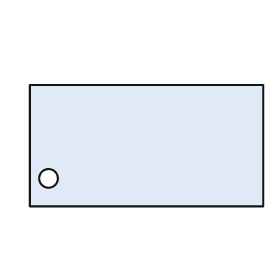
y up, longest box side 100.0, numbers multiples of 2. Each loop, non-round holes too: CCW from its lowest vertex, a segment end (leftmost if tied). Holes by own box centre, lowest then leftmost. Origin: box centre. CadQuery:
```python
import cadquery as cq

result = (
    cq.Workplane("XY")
    .moveTo(-50.0, -26.0)
    .lineTo(50.0, -26.0)
    .lineTo(50.0, 26.0)
    .lineTo(-50.0, 26.0)
    .close()
    .moveTo(-42.0, -14.0)
    .circle(4.0)
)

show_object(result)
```